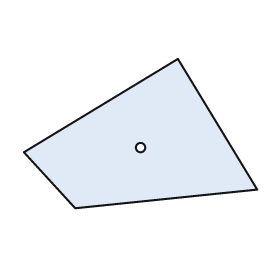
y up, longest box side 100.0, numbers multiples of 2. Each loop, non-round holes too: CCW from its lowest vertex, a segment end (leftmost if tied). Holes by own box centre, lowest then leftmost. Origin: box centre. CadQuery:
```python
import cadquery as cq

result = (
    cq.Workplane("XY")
    .moveTo(-28.0, -32.0)
    .lineTo(50.0, -24.0)
    .lineTo(16.0, 32.0)
    .lineTo(-50.0, -8.0)
    .close()
    .moveTo(0.0, -6.0)
    .circle(2.0)
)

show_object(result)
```